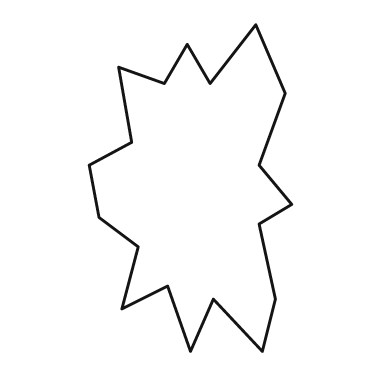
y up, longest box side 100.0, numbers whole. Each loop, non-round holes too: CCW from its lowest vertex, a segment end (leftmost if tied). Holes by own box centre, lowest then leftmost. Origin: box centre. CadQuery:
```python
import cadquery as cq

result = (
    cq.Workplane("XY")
    .moveTo(0.0, -50.0)
    .lineTo(7.0, -34.0)
    .lineTo(22.0, -50.0)
    .lineTo(26.0, -34.0)
    .lineTo(21.0, -11.0)
    .lineTo(31.0, -5.0)
    .lineTo(21.0, 7.0)
    .lineTo(29.0, 29.0)
    .lineTo(20.0, 50.0)
    .lineTo(6.0, 32.0)
    .lineTo(-1.0, 44.0)
    .lineTo(-8.0, 32.0)
    .lineTo(-22.0, 37.0)
    .lineTo(-18.0, 14.0)
    .lineTo(-31.0, 7.0)
    .lineTo(-28.0, -9.0)
    .lineTo(-16.0, -18.0)
    .lineTo(-21.0, -37.0)
    .lineTo(-7.0, -30.0)
    .close()
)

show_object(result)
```